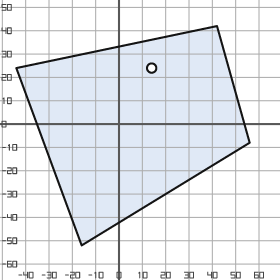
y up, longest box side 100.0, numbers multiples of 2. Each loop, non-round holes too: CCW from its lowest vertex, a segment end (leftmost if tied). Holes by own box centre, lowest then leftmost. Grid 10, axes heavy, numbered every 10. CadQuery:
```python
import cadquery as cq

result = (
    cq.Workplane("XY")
    .moveTo(-16.0, -52.0)
    .lineTo(56.0, -8.0)
    .lineTo(42.0, 42.0)
    .lineTo(-44.0, 24.0)
    .close()
    .moveTo(14.0, 24.0)
    .circle(2.0)
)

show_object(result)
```